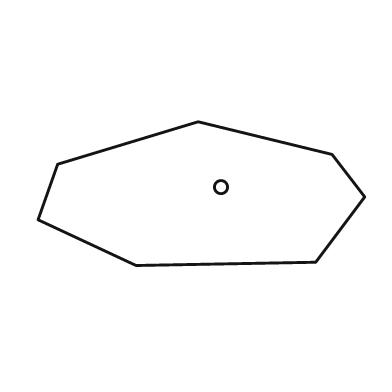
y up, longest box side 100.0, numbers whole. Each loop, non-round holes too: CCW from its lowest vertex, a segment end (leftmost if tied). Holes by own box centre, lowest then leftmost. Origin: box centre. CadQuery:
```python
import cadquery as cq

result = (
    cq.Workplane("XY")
    .moveTo(-20.0, -22.0)
    .lineTo(35.0, -21.0)
    .lineTo(50.0, -1.0)
    .lineTo(40.0, 12.0)
    .lineTo(-1.0, 22.0)
    .lineTo(-44.0, 9.0)
    .lineTo(-50.0, -8.0)
    .close()
    .moveTo(6.0, 2.0)
    .circle(2.0)
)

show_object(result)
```